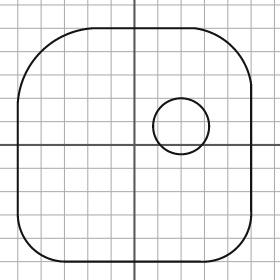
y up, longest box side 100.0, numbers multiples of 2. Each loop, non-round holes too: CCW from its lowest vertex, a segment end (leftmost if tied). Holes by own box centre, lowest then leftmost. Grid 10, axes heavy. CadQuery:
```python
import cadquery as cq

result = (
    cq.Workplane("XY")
    .moveTo(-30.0, -50.0)
    .lineTo(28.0, -50.0)
    .threePointArc((44.0, -44.0), (50.0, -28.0))
    .lineTo(50.0, 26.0)
    .threePointArc((42.0, 42.0), (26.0, 50.0))
    .lineTo(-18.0, 50.0)
    .threePointArc((-40.0, 40.0), (-50.0, 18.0))
    .lineTo(-50.0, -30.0)
    .threePointArc((-44.0, -44.0), (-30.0, -50.0))
    .close()
    .moveTo(20.0, 8.0)
    .circle(12.0)
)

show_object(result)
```